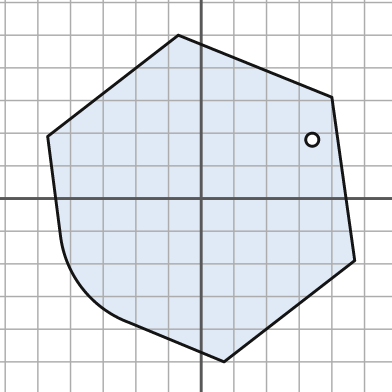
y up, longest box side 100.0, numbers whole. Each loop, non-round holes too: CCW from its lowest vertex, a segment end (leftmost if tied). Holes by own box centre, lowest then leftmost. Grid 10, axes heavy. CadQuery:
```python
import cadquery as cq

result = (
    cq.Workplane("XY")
    .moveTo(7.0, -50.0)
    .lineTo(47.0, -19.0)
    .lineTo(40.0, 31.0)
    .lineTo(-7.0, 50.0)
    .lineTo(-47.0, 19.0)
    .lineTo(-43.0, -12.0)
    .threePointArc((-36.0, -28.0), (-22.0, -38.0))
    .close()
    .moveTo(34.0, 18.0)
    .circle(2.0)
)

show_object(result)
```